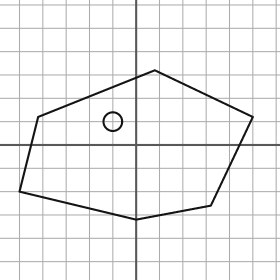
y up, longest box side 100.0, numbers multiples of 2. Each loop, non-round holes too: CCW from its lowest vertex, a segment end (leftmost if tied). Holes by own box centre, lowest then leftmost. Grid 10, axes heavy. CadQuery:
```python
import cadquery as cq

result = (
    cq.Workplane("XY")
    .moveTo(0.0, -32.0)
    .lineTo(32.0, -26.0)
    .lineTo(50.0, 12.0)
    .lineTo(8.0, 32.0)
    .lineTo(-42.0, 12.0)
    .lineTo(-50.0, -20.0)
    .close()
    .moveTo(-10.0, 10.0)
    .circle(4.0)
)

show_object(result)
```